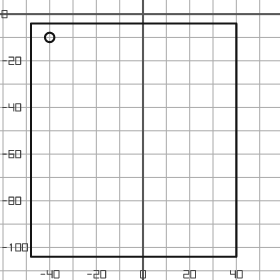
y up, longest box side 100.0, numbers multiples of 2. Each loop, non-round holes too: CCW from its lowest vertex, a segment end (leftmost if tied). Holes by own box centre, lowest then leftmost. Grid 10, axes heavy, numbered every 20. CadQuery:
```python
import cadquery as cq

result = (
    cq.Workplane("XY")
    .moveTo(-48.0, -104.0)
    .lineTo(40.0, -104.0)
    .lineTo(40.0, -4.0)
    .lineTo(-48.0, -4.0)
    .close()
    .moveTo(-40.0, -10.0)
    .circle(2.0)
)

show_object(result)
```